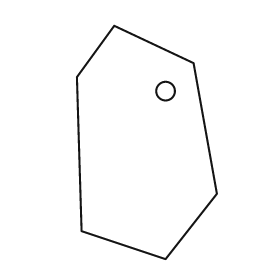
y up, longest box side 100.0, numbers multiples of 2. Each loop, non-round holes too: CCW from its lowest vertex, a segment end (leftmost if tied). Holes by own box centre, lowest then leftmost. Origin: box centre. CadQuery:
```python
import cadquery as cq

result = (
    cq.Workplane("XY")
    .moveTo(8.0, -50.0)
    .lineTo(30.0, -22.0)
    .lineTo(20.0, 34.0)
    .lineTo(-14.0, 50.0)
    .lineTo(-30.0, 28.0)
    .lineTo(-28.0, -38.0)
    .close()
    .moveTo(8.0, 22.0)
    .circle(4.0)
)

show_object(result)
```